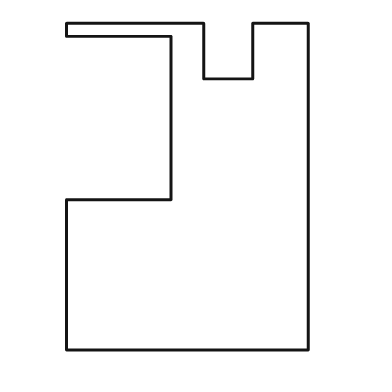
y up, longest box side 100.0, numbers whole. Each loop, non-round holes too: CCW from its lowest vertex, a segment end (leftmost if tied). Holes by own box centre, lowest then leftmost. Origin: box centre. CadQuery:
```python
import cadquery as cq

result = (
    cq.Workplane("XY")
    .moveTo(-37.0, -50.0)
    .lineTo(37.0, -50.0)
    .lineTo(37.0, 50.0)
    .lineTo(20.0, 50.0)
    .lineTo(20.0, 33.0)
    .lineTo(5.0, 33.0)
    .lineTo(5.0, 50.0)
    .lineTo(-37.0, 50.0)
    .lineTo(-37.0, 46.0)
    .lineTo(-5.0, 46.0)
    .lineTo(-5.0, -4.0)
    .lineTo(-37.0, -4.0)
    .close()
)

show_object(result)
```